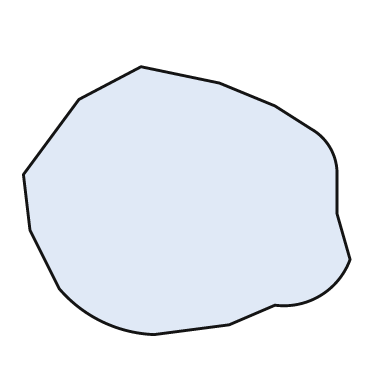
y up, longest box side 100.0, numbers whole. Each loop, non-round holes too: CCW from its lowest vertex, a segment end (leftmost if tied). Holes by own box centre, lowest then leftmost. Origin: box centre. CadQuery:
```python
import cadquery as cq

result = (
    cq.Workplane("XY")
    .moveTo(-10.0, -41.0)
    .lineTo(13.0, -38.0)
    .lineTo(27.0, -32.0)
    .threePointArc((41.0, -29.0), (50.0, -18.0))
    .lineTo(46.0, -4.0)
    .lineTo(46.0, 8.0)
    .threePointArc((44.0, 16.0), (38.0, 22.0))
    .lineTo(27.0, 29.0)
    .lineTo(10.0, 36.0)
    .lineTo(-14.0, 41.0)
    .lineTo(-33.0, 31.0)
    .lineTo(-50.0, 8.0)
    .lineTo(-48.0, -9.0)
    .lineTo(-39.0, -27.0)
    .threePointArc((-26.0, -37.0), (-10.0, -41.0))
    .close()
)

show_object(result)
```